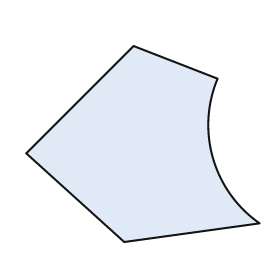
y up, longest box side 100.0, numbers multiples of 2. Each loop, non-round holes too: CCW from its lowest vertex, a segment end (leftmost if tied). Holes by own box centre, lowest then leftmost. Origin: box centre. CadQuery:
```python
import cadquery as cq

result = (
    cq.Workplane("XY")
    .moveTo(-8.0, -42.0)
    .lineTo(50.0, -34.0)
    .threePointArc((30.0, -6.0), (32.0, 28.0))
    .lineTo(-4.0, 42.0)
    .lineTo(-50.0, -4.0)
    .close()
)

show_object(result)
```